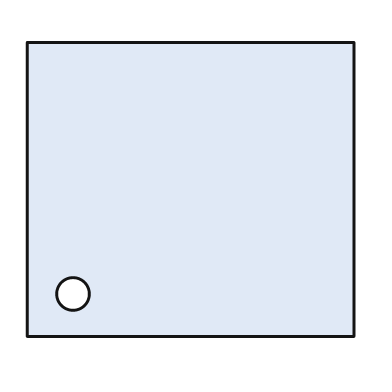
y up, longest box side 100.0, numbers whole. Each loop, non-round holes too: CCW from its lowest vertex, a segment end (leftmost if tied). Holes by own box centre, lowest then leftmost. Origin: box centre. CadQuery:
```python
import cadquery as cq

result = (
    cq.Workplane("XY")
    .moveTo(-50.0, -45.0)
    .lineTo(50.0, -45.0)
    .lineTo(50.0, 45.0)
    .lineTo(-50.0, 45.0)
    .close()
    .moveTo(-36.0, -32.0)
    .circle(5.0)
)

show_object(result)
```